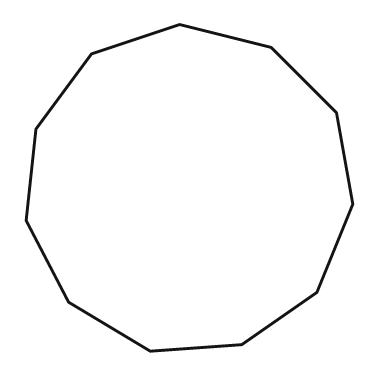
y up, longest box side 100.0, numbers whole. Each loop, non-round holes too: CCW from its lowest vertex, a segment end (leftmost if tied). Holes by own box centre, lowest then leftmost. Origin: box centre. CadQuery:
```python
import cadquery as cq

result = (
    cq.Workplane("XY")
    .moveTo(-12.0, -50.0)
    .lineTo(16.0, -48.0)
    .lineTo(39.0, -32.0)
    .lineTo(50.0, -5.0)
    .lineTo(45.0, 23.0)
    .lineTo(25.0, 43.0)
    .lineTo(-3.0, 50.0)
    .lineTo(-30.0, 41.0)
    .lineTo(-47.0, 18.0)
    .lineTo(-50.0, -10.0)
    .lineTo(-37.0, -35.0)
    .close()
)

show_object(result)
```